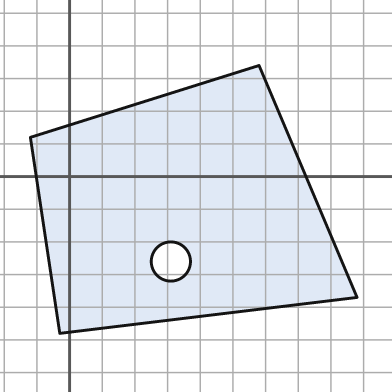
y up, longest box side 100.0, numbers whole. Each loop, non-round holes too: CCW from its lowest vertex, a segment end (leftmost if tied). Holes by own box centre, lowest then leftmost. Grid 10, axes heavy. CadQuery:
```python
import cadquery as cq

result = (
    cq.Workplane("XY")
    .moveTo(-3.0, -48.0)
    .lineTo(88.0, -37.0)
    .lineTo(58.0, 34.0)
    .lineTo(-12.0, 12.0)
    .close()
    .moveTo(31.0, -26.0)
    .circle(6.0)
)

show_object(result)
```